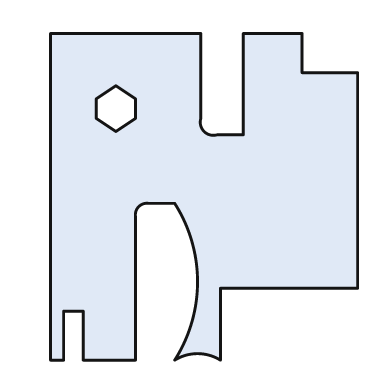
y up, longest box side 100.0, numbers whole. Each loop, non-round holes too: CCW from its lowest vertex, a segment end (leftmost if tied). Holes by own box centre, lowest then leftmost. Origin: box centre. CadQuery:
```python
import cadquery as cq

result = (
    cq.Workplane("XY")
    .moveTo(-47.0, -50.0)
    .lineTo(-43.0, -50.0)
    .lineTo(-43.0, -35.0)
    .lineTo(-37.0, -35.0)
    .lineTo(-37.0, -50.0)
    .lineTo(-21.0, -50.0)
    .lineTo(-21.0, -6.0)
    .threePointArc((-20.0, -3.0), (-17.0, -2.0))
    .lineTo(-9.0, -2.0)
    .threePointArc((-2.0, -26.0), (-9.0, -50.0))
    .threePointArc((-2.0, -48.0), (5.0, -50.0))
    .lineTo(5.0, -28.0)
    .lineTo(47.0, -28.0)
    .lineTo(47.0, 38.0)
    .lineTo(30.0, 38.0)
    .lineTo(30.0, 50.0)
    .lineTo(12.0, 50.0)
    .lineTo(12.0, 19.0)
    .lineTo(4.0, 19.0)
    .threePointArc((0.0, 20.0), (-1.0, 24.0))
    .lineTo(-1.0, 50.0)
    .lineTo(-47.0, 50.0)
    .close()
    .moveTo(-27.0, 20.0)
    .lineTo(-21.0, 24.0)
    .lineTo(-21.0, 30.0)
    .lineTo(-27.0, 34.0)
    .lineTo(-33.0, 30.0)
    .lineTo(-33.0, 24.0)
    .close()
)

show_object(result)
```